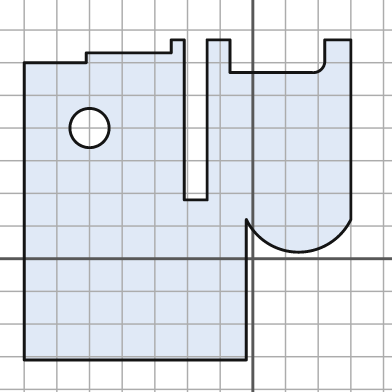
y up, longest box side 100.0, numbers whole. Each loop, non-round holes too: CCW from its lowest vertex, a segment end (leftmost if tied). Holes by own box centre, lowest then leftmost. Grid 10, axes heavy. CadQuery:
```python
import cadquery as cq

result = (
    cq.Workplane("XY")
    .moveTo(-70.0, -31.0)
    .lineTo(-2.0, -31.0)
    .lineTo(-2.0, 12.0)
    .threePointArc((14.0, 2.0), (30.0, 12.0))
    .lineTo(30.0, 67.0)
    .lineTo(22.0, 67.0)
    .lineTo(22.0, 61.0)
    .threePointArc((21.0, 58.0), (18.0, 57.0))
    .lineTo(-7.0, 57.0)
    .lineTo(-7.0, 67.0)
    .lineTo(-14.0, 67.0)
    .lineTo(-14.0, 18.0)
    .lineTo(-21.0, 18.0)
    .lineTo(-21.0, 67.0)
    .lineTo(-25.0, 67.0)
    .lineTo(-25.0, 63.0)
    .lineTo(-51.0, 63.0)
    .lineTo(-51.0, 60.0)
    .lineTo(-70.0, 60.0)
    .close()
    .moveTo(-50.0, 40.0)
    .circle(6.0)
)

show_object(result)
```